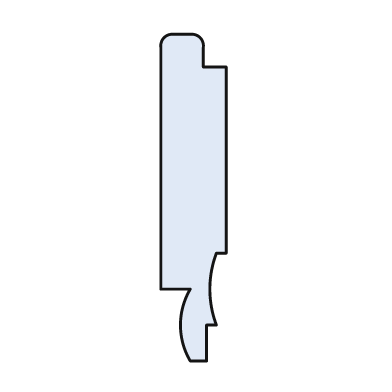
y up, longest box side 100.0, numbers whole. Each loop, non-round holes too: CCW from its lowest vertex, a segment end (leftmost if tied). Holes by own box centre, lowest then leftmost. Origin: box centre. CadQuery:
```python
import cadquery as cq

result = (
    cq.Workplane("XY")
    .moveTo(-1.0, -50.0)
    .lineTo(4.0, -50.0)
    .lineTo(4.0, -39.0)
    .lineTo(7.0, -39.0)
    .threePointArc((5.0, -28.0), (7.0, -17.0))
    .lineTo(10.0, -17.0)
    .lineTo(10.0, 40.0)
    .lineTo(3.0, 40.0)
    .lineTo(3.0, 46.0)
    .threePointArc((2.0, 49.0), (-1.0, 50.0))
    .lineTo(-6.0, 50.0)
    .threePointArc((-9.0, 49.0), (-10.0, 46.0))
    .lineTo(-10.0, -28.0)
    .lineTo(-1.0, -28.0)
    .threePointArc((-4.0, -39.0), (-1.0, -50.0))
    .close()
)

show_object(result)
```